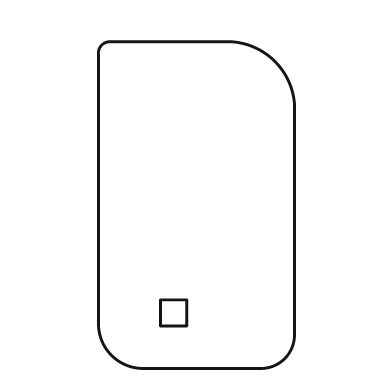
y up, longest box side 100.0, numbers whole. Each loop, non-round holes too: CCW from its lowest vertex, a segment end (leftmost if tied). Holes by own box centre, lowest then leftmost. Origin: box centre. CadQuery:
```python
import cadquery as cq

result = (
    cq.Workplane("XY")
    .moveTo(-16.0, -50.0)
    .lineTo(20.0, -50.0)
    .threePointArc((27.0, -47.0), (30.0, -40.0))
    .lineTo(30.0, 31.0)
    .threePointArc((24.0, 44.0), (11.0, 50.0))
    .lineTo(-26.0, 50.0)
    .threePointArc((-29.0, 49.0), (-30.0, 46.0))
    .lineTo(-30.0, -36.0)
    .threePointArc((-26.0, -46.0), (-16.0, -50.0))
    .close()
    .moveTo(-11.0, -37.0)
    .lineTo(-3.0, -37.0)
    .lineTo(-3.0, -29.0)
    .lineTo(-11.0, -29.0)
    .close()
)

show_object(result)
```